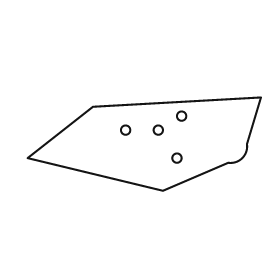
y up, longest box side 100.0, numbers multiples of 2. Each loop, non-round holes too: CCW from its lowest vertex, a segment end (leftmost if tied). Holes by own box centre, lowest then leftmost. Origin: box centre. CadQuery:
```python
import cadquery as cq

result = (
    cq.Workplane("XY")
    .moveTo(8.0, -20.0)
    .lineTo(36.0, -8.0)
    .threePointArc((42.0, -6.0), (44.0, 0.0))
    .lineTo(50.0, 20.0)
    .lineTo(-22.0, 16.0)
    .lineTo(-50.0, -6.0)
    .close()
    .moveTo(14.0, -6.0)
    .circle(2.0)
    .moveTo(-8.0, 6.0)
    .circle(2.0)
    .moveTo(6.0, 6.0)
    .circle(2.0)
    .moveTo(16.0, 12.0)
    .circle(2.0)
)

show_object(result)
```